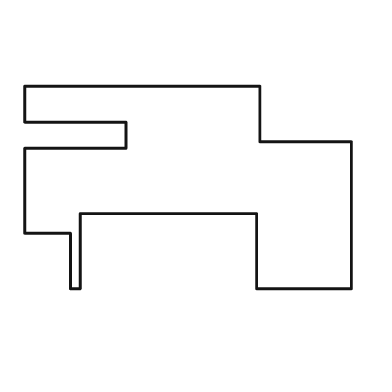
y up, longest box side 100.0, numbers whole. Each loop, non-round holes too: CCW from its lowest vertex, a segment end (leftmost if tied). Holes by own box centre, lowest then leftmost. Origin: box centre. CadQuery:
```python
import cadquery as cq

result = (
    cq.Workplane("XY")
    .moveTo(-36.0, -31.0)
    .lineTo(-33.0, -31.0)
    .lineTo(-33.0, -8.0)
    .lineTo(21.0, -8.0)
    .lineTo(21.0, -31.0)
    .lineTo(50.0, -31.0)
    .lineTo(50.0, 14.0)
    .lineTo(22.0, 14.0)
    .lineTo(22.0, 31.0)
    .lineTo(-50.0, 31.0)
    .lineTo(-50.0, 20.0)
    .lineTo(-19.0, 20.0)
    .lineTo(-19.0, 12.0)
    .lineTo(-50.0, 12.0)
    .lineTo(-50.0, -14.0)
    .lineTo(-36.0, -14.0)
    .close()
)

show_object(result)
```